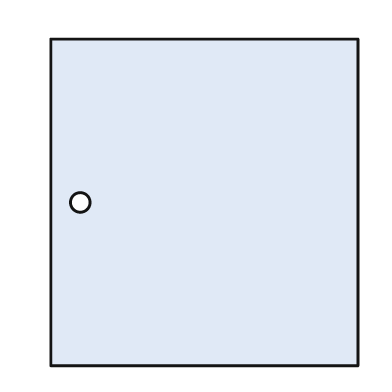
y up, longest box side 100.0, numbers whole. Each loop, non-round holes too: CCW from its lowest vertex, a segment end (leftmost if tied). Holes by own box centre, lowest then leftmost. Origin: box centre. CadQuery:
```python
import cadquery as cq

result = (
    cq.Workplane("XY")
    .moveTo(-47.0, -50.0)
    .lineTo(47.0, -50.0)
    .lineTo(47.0, 50.0)
    .lineTo(-47.0, 50.0)
    .close()
    .moveTo(-38.0, 0.0)
    .circle(3.0)
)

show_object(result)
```